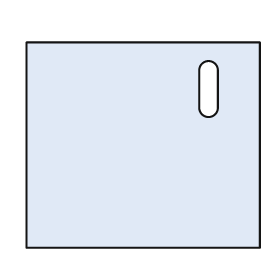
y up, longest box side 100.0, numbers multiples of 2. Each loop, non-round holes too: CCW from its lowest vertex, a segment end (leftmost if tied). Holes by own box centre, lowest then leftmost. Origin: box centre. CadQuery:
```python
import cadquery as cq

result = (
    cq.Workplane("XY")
    .moveTo(-50.0, -44.0)
    .lineTo(50.0, -44.0)
    .lineTo(50.0, 44.0)
    .lineTo(-50.0, 44.0)
    .close()
    .moveTo(24.0, 16.0)
    .threePointArc((28.0, 12.0), (32.0, 16.0))
    .lineTo(32.0, 32.0)
    .threePointArc((28.0, 36.0), (24.0, 32.0))
    .close()
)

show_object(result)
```